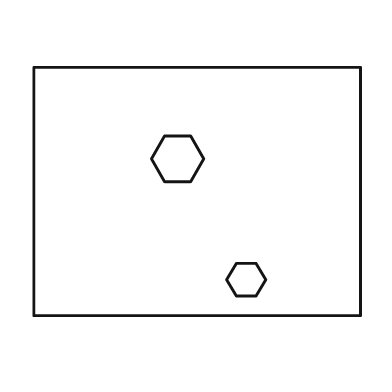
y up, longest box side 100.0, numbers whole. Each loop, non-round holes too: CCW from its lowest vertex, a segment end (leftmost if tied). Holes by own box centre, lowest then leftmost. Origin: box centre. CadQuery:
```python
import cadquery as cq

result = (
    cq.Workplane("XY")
    .moveTo(-50.0, -38.0)
    .lineTo(50.0, -38.0)
    .lineTo(50.0, 38.0)
    .lineTo(-50.0, 38.0)
    .close()
    .moveTo(12.0, -32.0)
    .lineTo(18.0, -32.0)
    .lineTo(21.0, -27.0)
    .lineTo(18.0, -22.0)
    .lineTo(12.0, -22.0)
    .lineTo(9.0, -27.0)
    .close()
    .moveTo(-10.0, 3.0)
    .lineTo(-2.0, 3.0)
    .lineTo(2.0, 10.0)
    .lineTo(-2.0, 17.0)
    .lineTo(-10.0, 17.0)
    .lineTo(-14.0, 10.0)
    .close()
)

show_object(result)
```